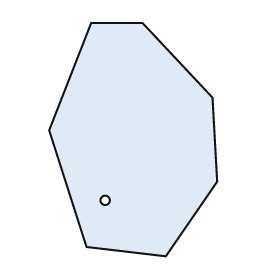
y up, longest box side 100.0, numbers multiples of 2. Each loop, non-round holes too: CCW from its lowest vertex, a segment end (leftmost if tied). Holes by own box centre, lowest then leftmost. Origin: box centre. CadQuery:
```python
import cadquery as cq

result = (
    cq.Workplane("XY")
    .moveTo(14.0, -50.0)
    .lineTo(36.0, -18.0)
    .lineTo(34.0, 18.0)
    .lineTo(4.0, 50.0)
    .lineTo(-18.0, 50.0)
    .lineTo(-36.0, 4.0)
    .lineTo(-20.0, -46.0)
    .close()
    .moveTo(-12.0, -26.0)
    .circle(2.0)
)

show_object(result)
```